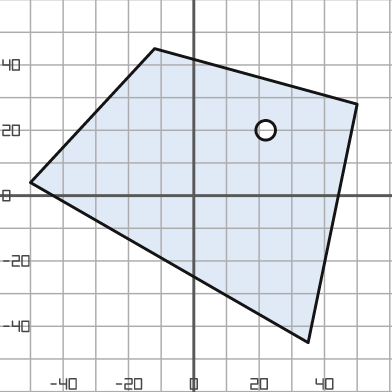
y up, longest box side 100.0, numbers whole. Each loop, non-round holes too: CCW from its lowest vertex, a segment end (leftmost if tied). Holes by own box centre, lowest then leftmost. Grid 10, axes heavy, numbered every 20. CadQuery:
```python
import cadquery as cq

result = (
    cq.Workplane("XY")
    .moveTo(35.0, -45.0)
    .lineTo(50.0, 28.0)
    .lineTo(-12.0, 45.0)
    .lineTo(-50.0, 4.0)
    .close()
    .moveTo(22.0, 20.0)
    .circle(3.0)
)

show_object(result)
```